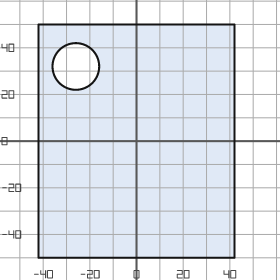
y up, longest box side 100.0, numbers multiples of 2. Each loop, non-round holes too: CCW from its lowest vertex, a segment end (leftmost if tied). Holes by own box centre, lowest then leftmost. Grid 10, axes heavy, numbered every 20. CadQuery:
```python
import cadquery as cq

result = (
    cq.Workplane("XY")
    .moveTo(-42.0, -50.0)
    .lineTo(42.0, -50.0)
    .lineTo(42.0, 50.0)
    .lineTo(-42.0, 50.0)
    .close()
    .moveTo(-26.0, 32.0)
    .circle(10.0)
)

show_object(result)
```